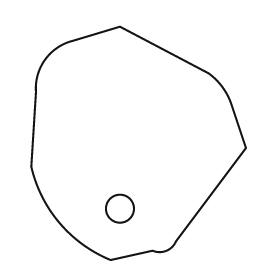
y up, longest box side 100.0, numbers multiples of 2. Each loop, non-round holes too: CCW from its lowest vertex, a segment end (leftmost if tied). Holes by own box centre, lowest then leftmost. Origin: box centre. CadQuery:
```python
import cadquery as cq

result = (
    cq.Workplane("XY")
    .moveTo(-12.0, -50.0)
    .lineTo(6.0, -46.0)
    .threePointArc((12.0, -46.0), (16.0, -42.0))
    .lineTo(46.0, -2.0)
    .lineTo(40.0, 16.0)
    .threePointArc((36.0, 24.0), (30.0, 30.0))
    .lineTo(-8.0, 50.0)
    .lineTo(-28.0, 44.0)
    .threePointArc((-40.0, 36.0), (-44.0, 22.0))
    .lineTo(-46.0, -10.0)
    .threePointArc((-34.0, -34.0), (-12.0, -50.0))
    .close()
    .moveTo(-8.0, -28.0)
    .circle(6.0)
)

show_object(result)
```